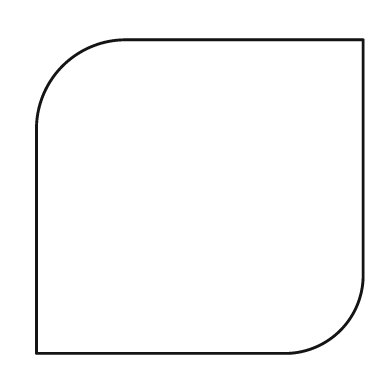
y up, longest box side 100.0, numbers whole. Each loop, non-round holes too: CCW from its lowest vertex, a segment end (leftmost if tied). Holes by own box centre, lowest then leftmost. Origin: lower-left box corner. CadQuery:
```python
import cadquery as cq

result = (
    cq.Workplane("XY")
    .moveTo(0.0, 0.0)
    .lineTo(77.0, 0.0)
    .threePointArc((93.0, 7.0), (100.0, 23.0))
    .lineTo(100.0, 96.0)
    .lineTo(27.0, 96.0)
    .threePointArc((8.0, 88.0), (0.0, 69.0))
    .close()
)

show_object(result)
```